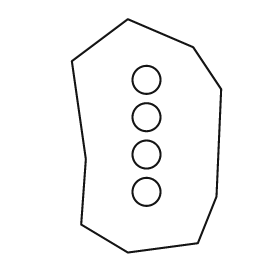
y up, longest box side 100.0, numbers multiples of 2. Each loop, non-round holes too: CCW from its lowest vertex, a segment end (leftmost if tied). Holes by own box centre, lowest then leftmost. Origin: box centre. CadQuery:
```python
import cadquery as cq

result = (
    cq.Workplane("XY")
    .moveTo(-8.0, -50.0)
    .lineTo(22.0, -46.0)
    .lineTo(30.0, -26.0)
    .lineTo(32.0, 20.0)
    .lineTo(20.0, 38.0)
    .lineTo(-8.0, 50.0)
    .lineTo(-32.0, 32.0)
    .lineTo(-26.0, -10.0)
    .lineTo(-28.0, -38.0)
    .close()
    .moveTo(0.0, -24.0)
    .circle(6.0)
    .moveTo(0.0, -8.0)
    .circle(6.0)
    .moveTo(0.0, 8.0)
    .circle(6.0)
    .moveTo(0.0, 24.0)
    .circle(6.0)
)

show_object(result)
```